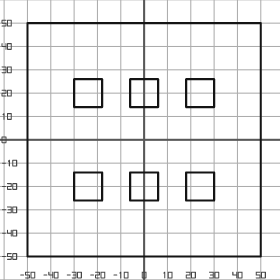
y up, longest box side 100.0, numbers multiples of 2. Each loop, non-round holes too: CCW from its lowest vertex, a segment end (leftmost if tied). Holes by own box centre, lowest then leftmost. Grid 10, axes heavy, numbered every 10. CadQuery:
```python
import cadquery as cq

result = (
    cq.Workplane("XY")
    .moveTo(-50.0, -50.0)
    .lineTo(50.0, -50.0)
    .lineTo(50.0, 50.0)
    .lineTo(-50.0, 50.0)
    .close()
    .moveTo(-30.0, -26.0)
    .lineTo(-18.0, -26.0)
    .lineTo(-18.0, -14.0)
    .lineTo(-30.0, -14.0)
    .close()
    .moveTo(-6.0, -26.0)
    .lineTo(6.0, -26.0)
    .lineTo(6.0, -14.0)
    .lineTo(-6.0, -14.0)
    .close()
    .moveTo(18.0, -26.0)
    .lineTo(30.0, -26.0)
    .lineTo(30.0, -14.0)
    .lineTo(18.0, -14.0)
    .close()
    .moveTo(-30.0, 14.0)
    .lineTo(-18.0, 14.0)
    .lineTo(-18.0, 26.0)
    .lineTo(-30.0, 26.0)
    .close()
    .moveTo(-6.0, 14.0)
    .lineTo(6.0, 14.0)
    .lineTo(6.0, 26.0)
    .lineTo(-6.0, 26.0)
    .close()
    .moveTo(18.0, 14.0)
    .lineTo(30.0, 14.0)
    .lineTo(30.0, 26.0)
    .lineTo(18.0, 26.0)
    .close()
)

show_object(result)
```